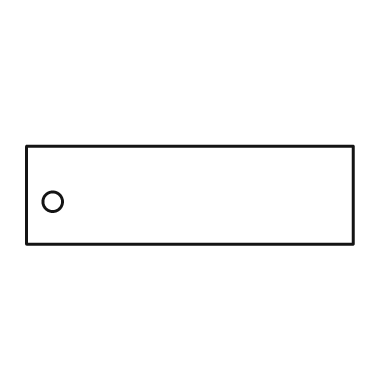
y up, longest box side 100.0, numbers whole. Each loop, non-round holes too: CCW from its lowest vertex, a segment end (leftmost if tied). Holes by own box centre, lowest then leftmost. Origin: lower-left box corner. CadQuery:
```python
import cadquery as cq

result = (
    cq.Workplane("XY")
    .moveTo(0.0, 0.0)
    .lineTo(100.0, 0.0)
    .lineTo(100.0, 30.0)
    .lineTo(0.0, 30.0)
    .close()
    .moveTo(8.0, 13.0)
    .circle(3.0)
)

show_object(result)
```